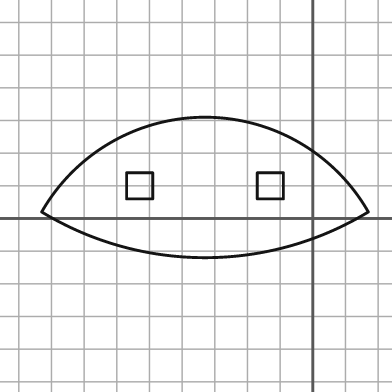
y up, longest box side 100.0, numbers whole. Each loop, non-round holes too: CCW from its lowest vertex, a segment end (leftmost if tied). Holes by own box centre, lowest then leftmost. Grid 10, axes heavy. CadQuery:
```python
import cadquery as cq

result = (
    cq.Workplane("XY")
    .moveTo(-83.0, 2.0)
    .threePointArc((-33.0, -12.0), (17.0, 2.0))
    .threePointArc((-33.0, 31.0), (-83.0, 2.0))
    .close()
    .moveTo(-57.0, 6.0)
    .lineTo(-49.0, 6.0)
    .lineTo(-49.0, 14.0)
    .lineTo(-57.0, 14.0)
    .close()
    .moveTo(-17.0, 6.0)
    .lineTo(-9.0, 6.0)
    .lineTo(-9.0, 14.0)
    .lineTo(-17.0, 14.0)
    .close()
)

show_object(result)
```